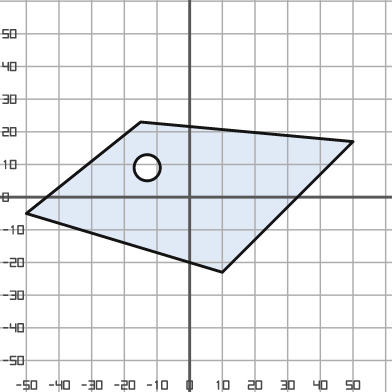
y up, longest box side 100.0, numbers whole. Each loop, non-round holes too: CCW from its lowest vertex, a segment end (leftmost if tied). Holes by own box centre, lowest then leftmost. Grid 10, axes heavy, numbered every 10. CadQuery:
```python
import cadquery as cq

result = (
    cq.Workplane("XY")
    .moveTo(10.0, -23.0)
    .lineTo(50.0, 17.0)
    .lineTo(-15.0, 23.0)
    .lineTo(-50.0, -5.0)
    .close()
    .moveTo(-13.0, 9.0)
    .circle(4.0)
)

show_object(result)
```